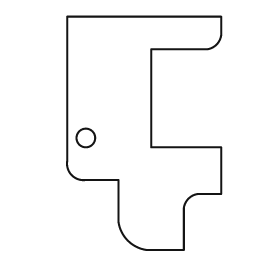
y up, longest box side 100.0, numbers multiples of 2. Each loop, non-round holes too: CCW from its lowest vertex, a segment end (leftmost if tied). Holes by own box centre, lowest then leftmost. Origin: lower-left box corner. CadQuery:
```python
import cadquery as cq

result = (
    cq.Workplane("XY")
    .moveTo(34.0, 0.0)
    .lineTo(50.0, 0.0)
    .lineTo(50.0, 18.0)
    .threePointArc((52.0, 22.0), (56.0, 24.0))
    .lineTo(66.0, 24.0)
    .lineTo(66.0, 44.0)
    .lineTo(36.0, 44.0)
    .lineTo(36.0, 86.0)
    .lineTo(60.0, 86.0)
    .threePointArc((64.0, 88.0), (66.0, 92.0))
    .lineTo(66.0, 100.0)
    .lineTo(0.0, 100.0)
    .lineTo(0.0, 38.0)
    .threePointArc((2.0, 32.0), (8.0, 30.0))
    .lineTo(22.0, 30.0)
    .lineTo(22.0, 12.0)
    .threePointArc((26.0, 4.0), (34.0, 0.0))
    .close()
    .moveTo(8.0, 48.0)
    .circle(4.0)
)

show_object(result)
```